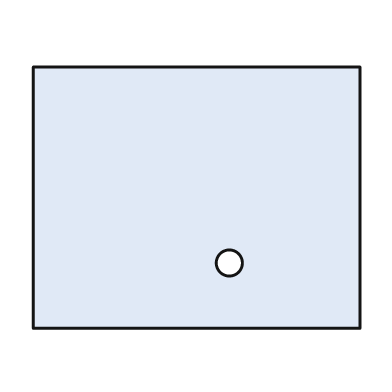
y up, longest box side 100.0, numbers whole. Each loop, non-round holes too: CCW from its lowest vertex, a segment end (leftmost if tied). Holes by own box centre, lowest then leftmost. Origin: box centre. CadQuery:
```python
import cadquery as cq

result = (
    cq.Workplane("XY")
    .moveTo(-50.0, -40.0)
    .lineTo(50.0, -40.0)
    .lineTo(50.0, 40.0)
    .lineTo(-50.0, 40.0)
    .close()
    .moveTo(10.0, -20.0)
    .circle(4.0)
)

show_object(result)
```